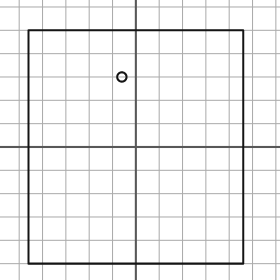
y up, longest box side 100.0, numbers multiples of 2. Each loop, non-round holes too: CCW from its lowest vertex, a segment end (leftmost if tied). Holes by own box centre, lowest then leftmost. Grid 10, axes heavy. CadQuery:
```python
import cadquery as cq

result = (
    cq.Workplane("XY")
    .moveTo(-46.0, -50.0)
    .lineTo(46.0, -50.0)
    .lineTo(46.0, 50.0)
    .lineTo(-46.0, 50.0)
    .close()
    .moveTo(-6.0, 30.0)
    .circle(2.0)
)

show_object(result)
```